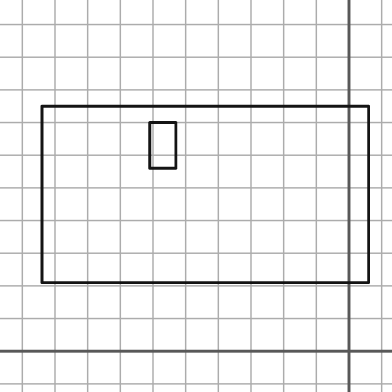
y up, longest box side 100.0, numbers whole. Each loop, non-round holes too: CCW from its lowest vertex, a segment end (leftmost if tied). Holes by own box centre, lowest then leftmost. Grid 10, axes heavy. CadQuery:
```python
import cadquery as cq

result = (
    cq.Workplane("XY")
    .moveTo(-94.0, 21.0)
    .lineTo(6.0, 21.0)
    .lineTo(6.0, 75.0)
    .lineTo(-94.0, 75.0)
    .close()
    .moveTo(-61.0, 56.0)
    .lineTo(-53.0, 56.0)
    .lineTo(-53.0, 70.0)
    .lineTo(-61.0, 70.0)
    .close()
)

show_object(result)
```